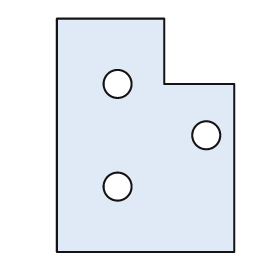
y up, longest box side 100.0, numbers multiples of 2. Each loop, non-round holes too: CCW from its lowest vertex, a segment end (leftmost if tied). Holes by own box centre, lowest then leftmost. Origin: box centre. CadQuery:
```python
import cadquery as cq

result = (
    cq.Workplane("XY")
    .moveTo(-38.0, -50.0)
    .lineTo(38.0, -50.0)
    .lineTo(38.0, 22.0)
    .lineTo(8.0, 22.0)
    .lineTo(8.0, 50.0)
    .lineTo(-38.0, 50.0)
    .close()
    .moveTo(-12.0, -22.0)
    .circle(6.0)
    .moveTo(26.0, 0.0)
    .circle(6.0)
    .moveTo(-12.0, 22.0)
    .circle(6.0)
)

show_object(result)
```